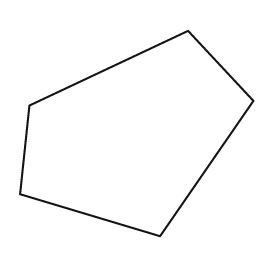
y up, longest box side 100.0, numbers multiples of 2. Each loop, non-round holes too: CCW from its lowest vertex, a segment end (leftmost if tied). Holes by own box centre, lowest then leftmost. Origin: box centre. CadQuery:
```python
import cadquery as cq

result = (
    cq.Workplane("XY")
    .moveTo(10.0, -44.0)
    .lineTo(50.0, 14.0)
    .lineTo(22.0, 44.0)
    .lineTo(-46.0, 12.0)
    .lineTo(-50.0, -26.0)
    .close()
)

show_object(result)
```